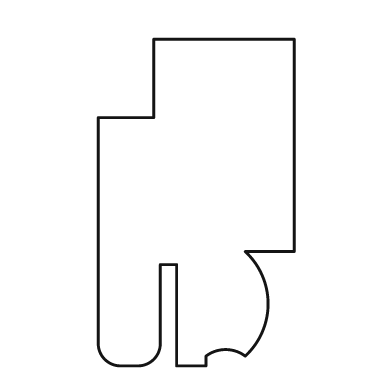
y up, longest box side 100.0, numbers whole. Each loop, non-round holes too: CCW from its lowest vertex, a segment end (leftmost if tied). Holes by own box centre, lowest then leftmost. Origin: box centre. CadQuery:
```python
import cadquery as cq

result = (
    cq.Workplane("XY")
    .moveTo(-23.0, -50.0)
    .lineTo(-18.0, -50.0)
    .threePointArc((-13.0, -48.0), (-11.0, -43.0))
    .lineTo(-11.0, -19.0)
    .lineTo(-6.0, -19.0)
    .lineTo(-6.0, -50.0)
    .lineTo(3.0, -50.0)
    .lineTo(3.0, -47.0)
    .threePointArc((9.0, -45.0), (15.0, -47.0))
    .threePointArc((22.0, -31.0), (15.0, -15.0))
    .lineTo(30.0, -15.0)
    .lineTo(30.0, 50.0)
    .lineTo(-13.0, 50.0)
    .lineTo(-13.0, 26.0)
    .lineTo(-30.0, 26.0)
    .lineTo(-30.0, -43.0)
    .threePointArc((-28.0, -48.0), (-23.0, -50.0))
    .close()
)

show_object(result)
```